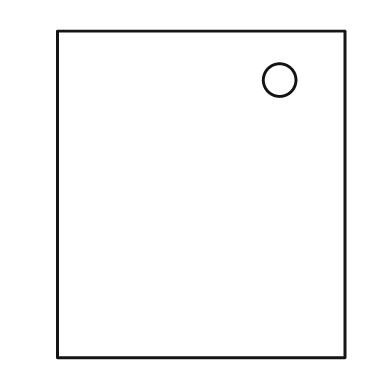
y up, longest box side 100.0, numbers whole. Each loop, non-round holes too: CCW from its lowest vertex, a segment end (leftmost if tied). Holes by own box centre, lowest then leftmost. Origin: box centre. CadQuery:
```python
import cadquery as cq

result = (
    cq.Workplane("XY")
    .moveTo(-44.0, -50.0)
    .lineTo(44.0, -50.0)
    .lineTo(44.0, 50.0)
    .lineTo(-44.0, 50.0)
    .close()
    .moveTo(24.0, 35.0)
    .circle(5.0)
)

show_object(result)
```